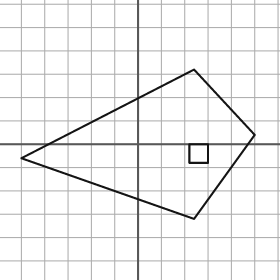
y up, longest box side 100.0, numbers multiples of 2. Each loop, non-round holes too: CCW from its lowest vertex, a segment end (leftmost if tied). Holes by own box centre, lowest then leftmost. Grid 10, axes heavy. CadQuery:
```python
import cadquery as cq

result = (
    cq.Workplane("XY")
    .moveTo(24.0, -32.0)
    .lineTo(50.0, 4.0)
    .lineTo(24.0, 32.0)
    .lineTo(-50.0, -6.0)
    .close()
    .moveTo(22.0, -8.0)
    .lineTo(30.0, -8.0)
    .lineTo(30.0, 0.0)
    .lineTo(22.0, 0.0)
    .close()
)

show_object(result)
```